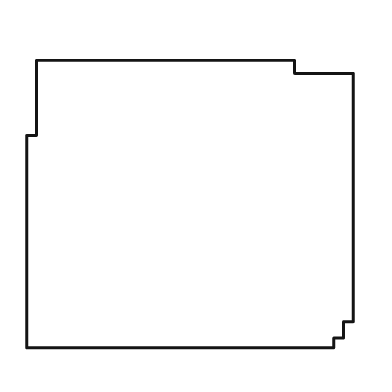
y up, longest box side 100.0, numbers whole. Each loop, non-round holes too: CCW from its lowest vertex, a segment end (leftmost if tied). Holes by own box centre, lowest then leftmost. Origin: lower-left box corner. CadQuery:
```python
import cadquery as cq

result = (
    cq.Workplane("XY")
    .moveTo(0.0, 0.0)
    .lineTo(94.0, 0.0)
    .lineTo(94.0, 3.0)
    .lineTo(97.0, 3.0)
    .lineTo(97.0, 8.0)
    .lineTo(100.0, 8.0)
    .lineTo(100.0, 84.0)
    .lineTo(82.0, 84.0)
    .lineTo(82.0, 88.0)
    .lineTo(3.0, 88.0)
    .lineTo(3.0, 65.0)
    .lineTo(0.0, 65.0)
    .close()
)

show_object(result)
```